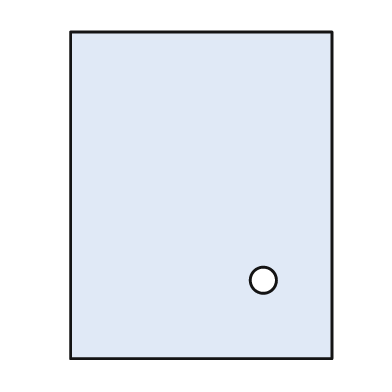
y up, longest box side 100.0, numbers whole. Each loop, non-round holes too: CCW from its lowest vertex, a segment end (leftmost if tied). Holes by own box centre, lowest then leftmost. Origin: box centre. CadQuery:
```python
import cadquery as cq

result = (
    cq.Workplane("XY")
    .moveTo(-40.0, -50.0)
    .lineTo(40.0, -50.0)
    .lineTo(40.0, 50.0)
    .lineTo(-40.0, 50.0)
    .close()
    .moveTo(19.0, -26.0)
    .circle(4.0)
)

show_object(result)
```